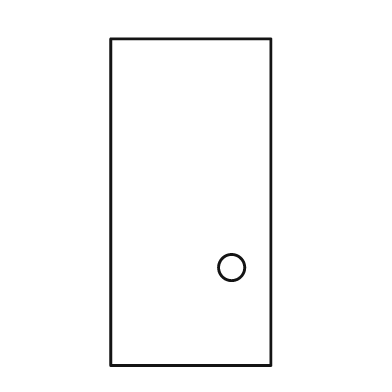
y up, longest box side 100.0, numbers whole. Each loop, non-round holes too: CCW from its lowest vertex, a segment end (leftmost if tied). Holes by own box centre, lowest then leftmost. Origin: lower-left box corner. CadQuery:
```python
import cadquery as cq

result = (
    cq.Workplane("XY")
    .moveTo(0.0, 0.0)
    .lineTo(49.0, 0.0)
    .lineTo(49.0, 100.0)
    .lineTo(0.0, 100.0)
    .close()
    .moveTo(37.0, 30.0)
    .circle(4.0)
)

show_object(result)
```